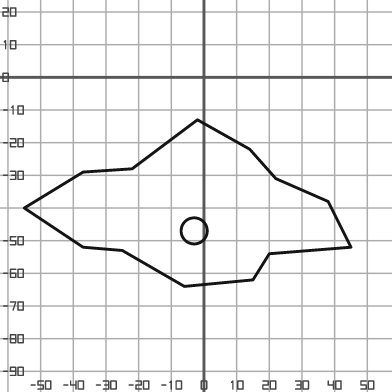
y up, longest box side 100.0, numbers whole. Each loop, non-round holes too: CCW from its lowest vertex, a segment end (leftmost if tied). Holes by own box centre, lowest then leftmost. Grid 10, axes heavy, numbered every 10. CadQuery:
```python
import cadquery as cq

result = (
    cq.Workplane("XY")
    .moveTo(-6.0, -64.0)
    .lineTo(15.0, -62.0)
    .lineTo(20.0, -54.0)
    .lineTo(45.0, -52.0)
    .lineTo(38.0, -38.0)
    .lineTo(22.0, -31.0)
    .lineTo(14.0, -22.0)
    .lineTo(-2.0, -13.0)
    .lineTo(-22.0, -28.0)
    .lineTo(-37.0, -29.0)
    .lineTo(-55.0, -40.0)
    .lineTo(-37.0, -52.0)
    .lineTo(-25.0, -53.0)
    .close()
    .moveTo(-3.0, -47.0)
    .circle(4.0)
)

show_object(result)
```